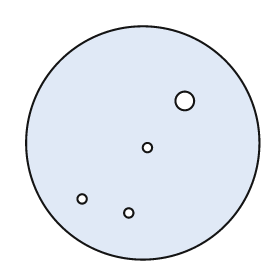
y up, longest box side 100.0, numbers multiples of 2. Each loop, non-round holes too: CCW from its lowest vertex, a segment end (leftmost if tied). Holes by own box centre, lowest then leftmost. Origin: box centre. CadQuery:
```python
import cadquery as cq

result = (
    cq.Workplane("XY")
    .moveTo(0.0, 0.0)
    .circle(50.0)
    .moveTo(-6.0, -30.0)
    .circle(2.0)
    .moveTo(-26.0, -24.0)
    .circle(2.0)
    .moveTo(2.0, -2.0)
    .circle(2.0)
    .moveTo(18.0, 18.0)
    .circle(4.0)
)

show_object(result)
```